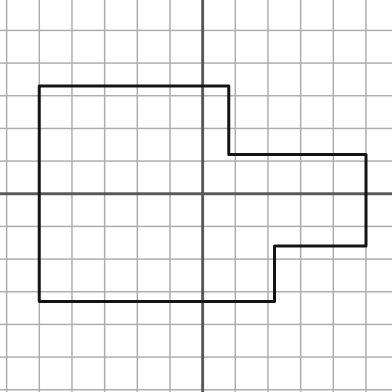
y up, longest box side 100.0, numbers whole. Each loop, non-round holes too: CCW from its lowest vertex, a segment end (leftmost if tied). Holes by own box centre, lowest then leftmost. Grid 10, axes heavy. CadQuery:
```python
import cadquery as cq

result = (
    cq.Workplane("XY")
    .moveTo(-50.0, -33.0)
    .lineTo(22.0, -33.0)
    .lineTo(22.0, -16.0)
    .lineTo(50.0, -16.0)
    .lineTo(50.0, 12.0)
    .lineTo(8.0, 12.0)
    .lineTo(8.0, 33.0)
    .lineTo(-50.0, 33.0)
    .close()
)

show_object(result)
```